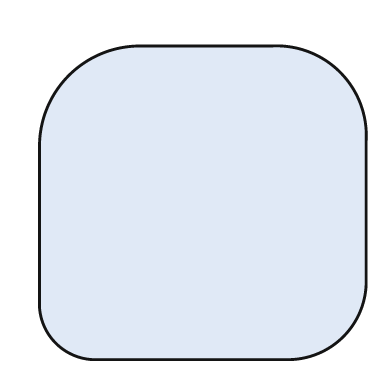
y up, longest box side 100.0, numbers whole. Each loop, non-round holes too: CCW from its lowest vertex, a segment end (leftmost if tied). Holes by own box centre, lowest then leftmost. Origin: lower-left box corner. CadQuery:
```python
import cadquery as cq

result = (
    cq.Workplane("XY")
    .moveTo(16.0, 0.0)
    .lineTo(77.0, 0.0)
    .threePointArc((93.0, 7.0), (100.0, 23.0))
    .lineTo(100.0, 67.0)
    .threePointArc((92.0, 88.0), (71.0, 96.0))
    .lineTo(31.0, 96.0)
    .threePointArc((9.0, 87.0), (0.0, 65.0))
    .lineTo(0.0, 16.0)
    .threePointArc((5.0, 5.0), (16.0, 0.0))
    .close()
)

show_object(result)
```